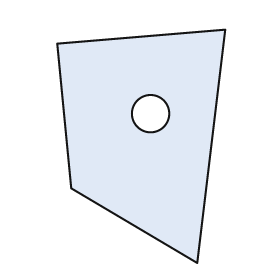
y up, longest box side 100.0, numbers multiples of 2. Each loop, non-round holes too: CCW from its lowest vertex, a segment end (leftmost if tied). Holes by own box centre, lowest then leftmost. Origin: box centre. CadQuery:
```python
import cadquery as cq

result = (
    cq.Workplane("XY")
    .moveTo(24.0, -50.0)
    .lineTo(36.0, 50.0)
    .lineTo(-36.0, 44.0)
    .lineTo(-30.0, -18.0)
    .close()
    .moveTo(4.0, 14.0)
    .circle(8.0)
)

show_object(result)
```